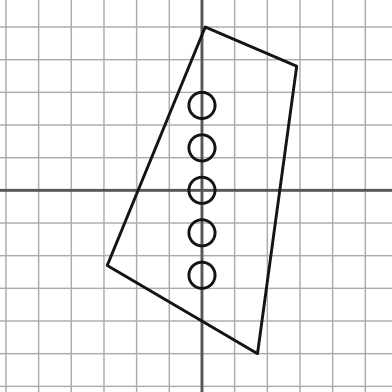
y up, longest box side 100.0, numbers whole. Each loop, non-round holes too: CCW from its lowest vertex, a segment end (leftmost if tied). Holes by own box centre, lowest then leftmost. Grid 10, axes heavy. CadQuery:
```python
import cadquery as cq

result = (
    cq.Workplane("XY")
    .moveTo(17.0, -50.0)
    .lineTo(29.0, 38.0)
    .lineTo(1.0, 50.0)
    .lineTo(-29.0, -23.0)
    .close()
    .moveTo(0.0, -26.0)
    .circle(4.0)
    .moveTo(0.0, -13.0)
    .circle(4.0)
    .moveTo(0.0, 0.0)
    .circle(4.0)
    .moveTo(0.0, 13.0)
    .circle(4.0)
    .moveTo(0.0, 26.0)
    .circle(4.0)
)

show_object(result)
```